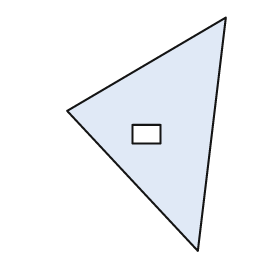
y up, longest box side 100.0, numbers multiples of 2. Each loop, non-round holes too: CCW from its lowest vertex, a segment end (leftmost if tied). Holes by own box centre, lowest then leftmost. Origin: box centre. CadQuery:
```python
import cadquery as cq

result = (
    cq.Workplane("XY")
    .moveTo(22.0, -50.0)
    .lineTo(34.0, 50.0)
    .lineTo(-34.0, 10.0)
    .close()
    .moveTo(-6.0, -4.0)
    .lineTo(6.0, -4.0)
    .lineTo(6.0, 4.0)
    .lineTo(-6.0, 4.0)
    .close()
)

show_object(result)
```